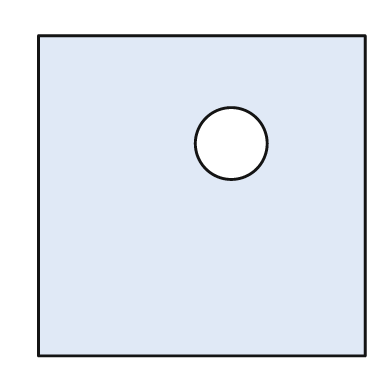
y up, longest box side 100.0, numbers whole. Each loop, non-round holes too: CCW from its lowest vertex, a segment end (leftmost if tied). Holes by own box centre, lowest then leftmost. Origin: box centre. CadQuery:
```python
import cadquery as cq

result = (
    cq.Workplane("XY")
    .moveTo(-50.0, -49.0)
    .lineTo(50.0, -49.0)
    .lineTo(50.0, 49.0)
    .lineTo(-50.0, 49.0)
    .close()
    .moveTo(9.0, 16.0)
    .circle(11.0)
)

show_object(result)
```